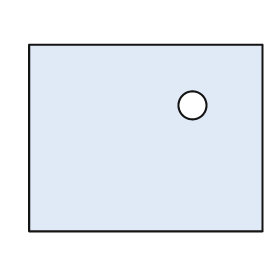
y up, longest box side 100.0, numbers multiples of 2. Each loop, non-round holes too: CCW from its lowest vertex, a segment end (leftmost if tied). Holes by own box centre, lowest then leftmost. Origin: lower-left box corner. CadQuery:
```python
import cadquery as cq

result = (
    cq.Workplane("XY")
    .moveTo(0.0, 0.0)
    .lineTo(100.0, 0.0)
    .lineTo(100.0, 80.0)
    .lineTo(0.0, 80.0)
    .close()
    .moveTo(70.0, 54.0)
    .circle(6.0)
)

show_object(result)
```